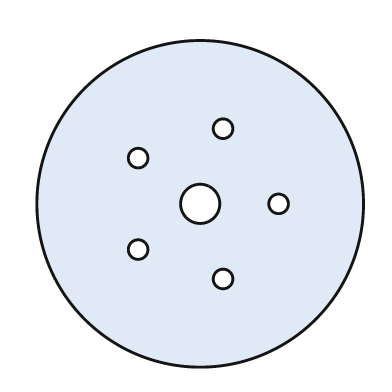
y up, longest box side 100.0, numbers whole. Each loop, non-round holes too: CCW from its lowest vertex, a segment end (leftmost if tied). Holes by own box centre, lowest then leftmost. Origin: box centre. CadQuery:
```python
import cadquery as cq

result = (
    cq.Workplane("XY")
    .moveTo(0.0, 0.0)
    .circle(50.0)
    .moveTo(7.0, -23.0)
    .circle(3.0)
    .moveTo(-19.0, -14.0)
    .circle(3.0)
    .moveTo(0.0, 0.0)
    .circle(6.0)
    .moveTo(24.0, 0.0)
    .circle(3.0)
    .moveTo(-19.0, 14.0)
    .circle(3.0)
    .moveTo(7.0, 23.0)
    .circle(3.0)
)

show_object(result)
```